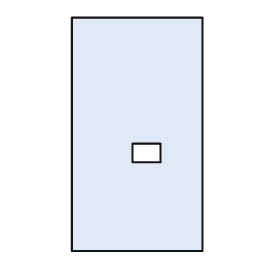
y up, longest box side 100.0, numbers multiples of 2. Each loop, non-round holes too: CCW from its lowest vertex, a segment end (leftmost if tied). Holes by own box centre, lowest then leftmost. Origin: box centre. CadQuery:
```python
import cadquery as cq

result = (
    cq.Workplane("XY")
    .moveTo(-28.0, -50.0)
    .lineTo(28.0, -50.0)
    .lineTo(28.0, 50.0)
    .lineTo(-28.0, 50.0)
    .close()
    .moveTo(-2.0, -12.0)
    .lineTo(10.0, -12.0)
    .lineTo(10.0, -4.0)
    .lineTo(-2.0, -4.0)
    .close()
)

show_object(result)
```